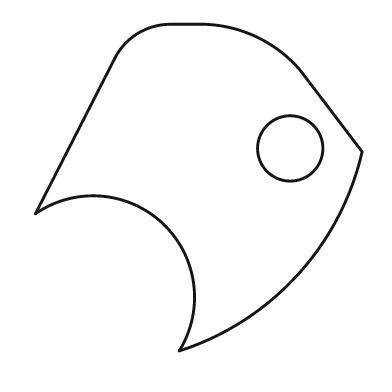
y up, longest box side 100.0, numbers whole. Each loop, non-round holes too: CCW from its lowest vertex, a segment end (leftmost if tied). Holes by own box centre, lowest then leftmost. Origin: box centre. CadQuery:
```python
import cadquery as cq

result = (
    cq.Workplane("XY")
    .moveTo(-6.0, -50.0)
    .threePointArc((30.0, -27.0), (50.0, 11.0))
    .lineTo(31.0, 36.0)
    .threePointArc((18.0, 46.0), (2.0, 50.0))
    .lineTo(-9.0, 50.0)
    .threePointArc((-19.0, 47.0), (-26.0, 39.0))
    .lineTo(-50.0, -8.0)
    .threePointArc((-11.0, -11.0), (-6.0, -50.0))
    .close()
    .moveTo(28.0, 12.0)
    .circle(10.0)
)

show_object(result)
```